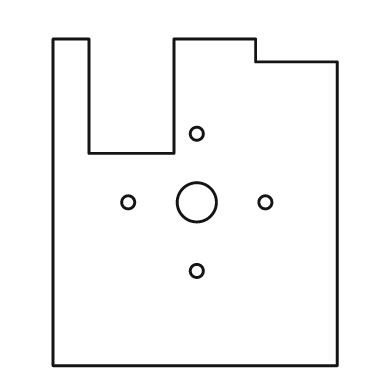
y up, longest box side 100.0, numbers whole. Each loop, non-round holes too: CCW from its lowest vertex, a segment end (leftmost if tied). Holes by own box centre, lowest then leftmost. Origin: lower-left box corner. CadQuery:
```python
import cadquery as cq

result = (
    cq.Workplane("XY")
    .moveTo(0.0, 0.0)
    .lineTo(87.0, 0.0)
    .lineTo(87.0, 93.0)
    .lineTo(62.0, 93.0)
    .lineTo(62.0, 100.0)
    .lineTo(37.0, 100.0)
    .lineTo(37.0, 65.0)
    .lineTo(11.0, 65.0)
    .lineTo(11.0, 100.0)
    .lineTo(0.0, 100.0)
    .close()
    .moveTo(44.0, 29.0)
    .circle(2.0)
    .moveTo(23.0, 50.0)
    .circle(2.0)
    .moveTo(44.0, 50.0)
    .circle(6.0)
    .moveTo(65.0, 50.0)
    .circle(2.0)
    .moveTo(44.0, 71.0)
    .circle(2.0)
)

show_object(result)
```